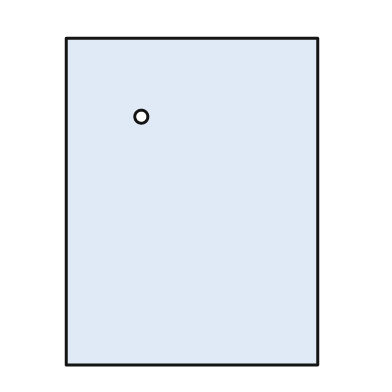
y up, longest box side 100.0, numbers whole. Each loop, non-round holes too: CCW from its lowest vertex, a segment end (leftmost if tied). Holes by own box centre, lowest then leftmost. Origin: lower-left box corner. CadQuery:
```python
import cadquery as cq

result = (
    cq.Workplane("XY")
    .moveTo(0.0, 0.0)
    .lineTo(77.0, 0.0)
    .lineTo(77.0, 100.0)
    .lineTo(0.0, 100.0)
    .close()
    .moveTo(23.0, 76.0)
    .circle(2.0)
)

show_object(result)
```